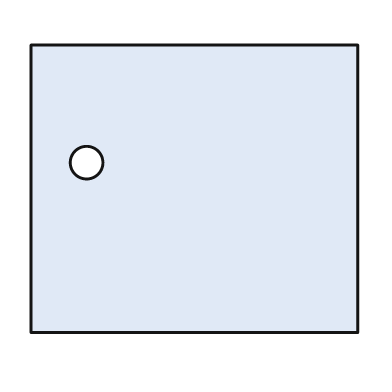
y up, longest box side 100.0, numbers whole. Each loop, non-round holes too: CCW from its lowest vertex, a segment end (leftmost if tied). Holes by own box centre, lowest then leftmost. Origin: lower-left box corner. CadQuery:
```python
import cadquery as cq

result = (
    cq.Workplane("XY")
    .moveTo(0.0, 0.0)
    .lineTo(100.0, 0.0)
    .lineTo(100.0, 88.0)
    .lineTo(0.0, 88.0)
    .close()
    .moveTo(17.0, 52.0)
    .circle(5.0)
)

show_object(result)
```